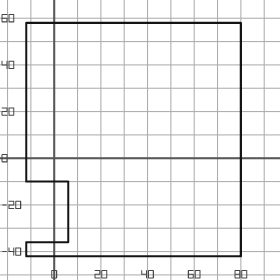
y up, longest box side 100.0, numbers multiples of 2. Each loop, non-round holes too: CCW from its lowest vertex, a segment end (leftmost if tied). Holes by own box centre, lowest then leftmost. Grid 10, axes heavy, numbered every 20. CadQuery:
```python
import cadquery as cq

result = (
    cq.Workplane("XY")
    .moveTo(-12.0, -42.0)
    .lineTo(80.0, -42.0)
    .lineTo(80.0, 58.0)
    .lineTo(-12.0, 58.0)
    .lineTo(-12.0, -10.0)
    .lineTo(6.0, -10.0)
    .lineTo(6.0, -36.0)
    .lineTo(-12.0, -36.0)
    .close()
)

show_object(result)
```